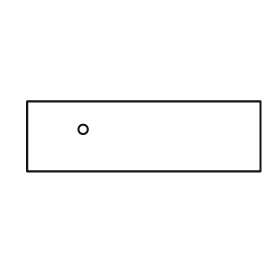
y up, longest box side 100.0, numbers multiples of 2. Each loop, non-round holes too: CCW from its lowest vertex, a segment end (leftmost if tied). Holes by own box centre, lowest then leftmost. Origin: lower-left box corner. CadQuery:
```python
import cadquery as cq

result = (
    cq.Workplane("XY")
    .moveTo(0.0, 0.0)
    .lineTo(100.0, 0.0)
    .lineTo(100.0, 30.0)
    .lineTo(0.0, 30.0)
    .close()
    .moveTo(24.0, 18.0)
    .circle(2.0)
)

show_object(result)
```